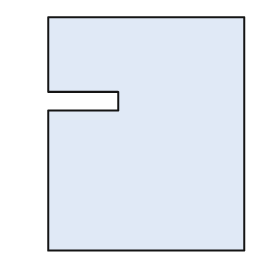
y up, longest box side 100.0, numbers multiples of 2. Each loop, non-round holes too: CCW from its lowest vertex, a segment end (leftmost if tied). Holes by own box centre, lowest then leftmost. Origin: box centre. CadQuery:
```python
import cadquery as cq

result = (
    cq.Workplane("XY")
    .moveTo(-42.0, -50.0)
    .lineTo(42.0, -50.0)
    .lineTo(42.0, 50.0)
    .lineTo(-42.0, 50.0)
    .lineTo(-42.0, 18.0)
    .lineTo(-12.0, 18.0)
    .lineTo(-12.0, 10.0)
    .lineTo(-42.0, 10.0)
    .close()
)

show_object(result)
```